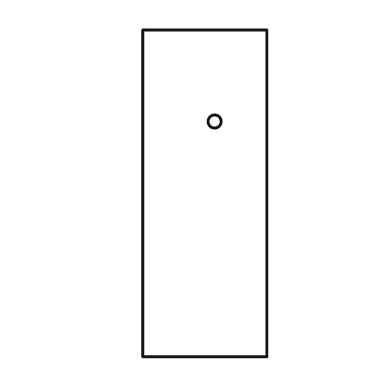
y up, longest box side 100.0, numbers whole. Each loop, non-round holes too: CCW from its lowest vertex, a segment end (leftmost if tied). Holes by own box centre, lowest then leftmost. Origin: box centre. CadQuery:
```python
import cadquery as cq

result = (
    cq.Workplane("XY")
    .moveTo(-19.0, -50.0)
    .lineTo(19.0, -50.0)
    .lineTo(19.0, 50.0)
    .lineTo(-19.0, 50.0)
    .close()
    .moveTo(3.0, 22.0)
    .circle(2.0)
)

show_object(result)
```